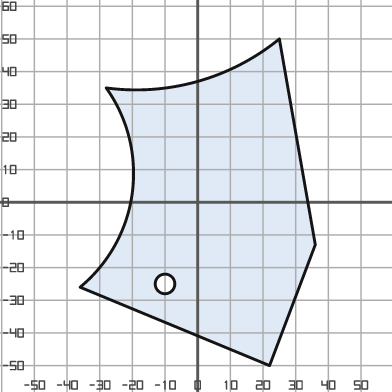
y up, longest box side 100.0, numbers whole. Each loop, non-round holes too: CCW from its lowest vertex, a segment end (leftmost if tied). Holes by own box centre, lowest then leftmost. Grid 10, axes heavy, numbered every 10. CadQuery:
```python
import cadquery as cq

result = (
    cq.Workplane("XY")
    .moveTo(22.0, -50.0)
    .lineTo(36.0, -13.0)
    .lineTo(25.0, 50.0)
    .threePointArc((0.0, 37.0), (-28.0, 35.0))
    .threePointArc((-20.0, 3.0), (-36.0, -26.0))
    .close()
    .moveTo(-10.0, -25.0)
    .circle(3.0)
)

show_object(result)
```